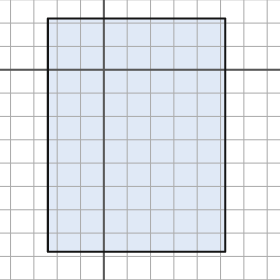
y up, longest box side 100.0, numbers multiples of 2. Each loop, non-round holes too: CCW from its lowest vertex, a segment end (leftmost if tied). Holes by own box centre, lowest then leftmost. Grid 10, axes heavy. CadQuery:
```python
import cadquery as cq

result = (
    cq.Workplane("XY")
    .moveTo(-24.0, -78.0)
    .lineTo(52.0, -78.0)
    .lineTo(52.0, 22.0)
    .lineTo(-24.0, 22.0)
    .close()
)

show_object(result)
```